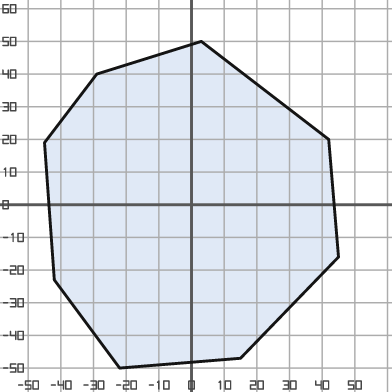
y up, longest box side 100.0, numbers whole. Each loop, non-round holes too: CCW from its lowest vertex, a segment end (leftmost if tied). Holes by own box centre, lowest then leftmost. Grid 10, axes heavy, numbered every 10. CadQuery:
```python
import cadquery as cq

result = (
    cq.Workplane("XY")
    .moveTo(-22.0, -50.0)
    .lineTo(15.0, -47.0)
    .lineTo(45.0, -16.0)
    .lineTo(42.0, 20.0)
    .lineTo(3.0, 50.0)
    .lineTo(-29.0, 40.0)
    .lineTo(-45.0, 19.0)
    .lineTo(-42.0, -23.0)
    .close()
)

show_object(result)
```